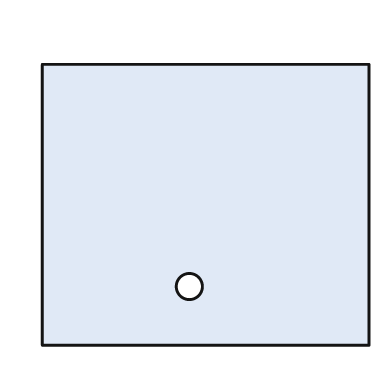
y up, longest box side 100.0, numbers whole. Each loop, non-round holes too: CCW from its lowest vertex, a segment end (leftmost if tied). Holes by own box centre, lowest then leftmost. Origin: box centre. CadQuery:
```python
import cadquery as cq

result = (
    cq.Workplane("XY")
    .moveTo(-50.0, -43.0)
    .lineTo(50.0, -43.0)
    .lineTo(50.0, 43.0)
    .lineTo(-50.0, 43.0)
    .close()
    .moveTo(-5.0, -25.0)
    .circle(4.0)
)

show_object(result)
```